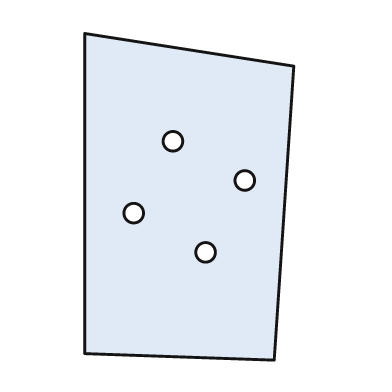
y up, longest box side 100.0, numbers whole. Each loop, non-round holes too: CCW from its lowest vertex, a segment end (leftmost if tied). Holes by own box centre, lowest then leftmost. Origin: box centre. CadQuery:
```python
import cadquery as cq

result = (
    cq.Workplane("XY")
    .moveTo(26.0, -50.0)
    .lineTo(32.0, 40.0)
    .lineTo(-32.0, 50.0)
    .lineTo(-32.0, -48.0)
    .close()
    .moveTo(5.0, -17.0)
    .circle(3.0)
    .moveTo(-17.0, -5.0)
    .circle(3.0)
    .moveTo(17.0, 5.0)
    .circle(3.0)
    .moveTo(-5.0, 17.0)
    .circle(3.0)
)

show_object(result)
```